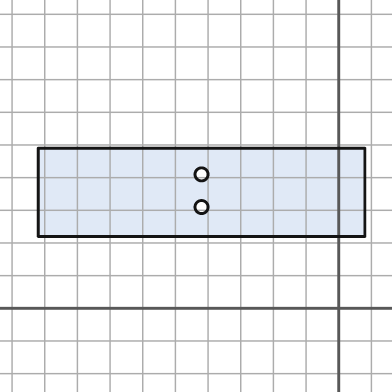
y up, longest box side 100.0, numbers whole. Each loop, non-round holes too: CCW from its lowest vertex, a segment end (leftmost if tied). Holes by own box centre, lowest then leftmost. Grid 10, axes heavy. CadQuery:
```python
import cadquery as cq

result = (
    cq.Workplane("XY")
    .moveTo(-92.0, 22.0)
    .lineTo(8.0, 22.0)
    .lineTo(8.0, 49.0)
    .lineTo(-92.0, 49.0)
    .close()
    .moveTo(-42.0, 31.0)
    .circle(2.0)
    .moveTo(-42.0, 41.0)
    .circle(2.0)
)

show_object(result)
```